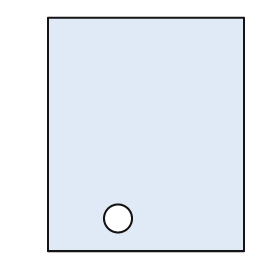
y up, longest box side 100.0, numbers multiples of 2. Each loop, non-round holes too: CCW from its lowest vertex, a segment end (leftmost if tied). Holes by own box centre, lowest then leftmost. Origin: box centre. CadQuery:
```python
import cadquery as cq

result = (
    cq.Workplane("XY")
    .moveTo(-42.0, -50.0)
    .lineTo(42.0, -50.0)
    .lineTo(42.0, 50.0)
    .lineTo(-42.0, 50.0)
    .close()
    .moveTo(-12.0, -36.0)
    .circle(6.0)
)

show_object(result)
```